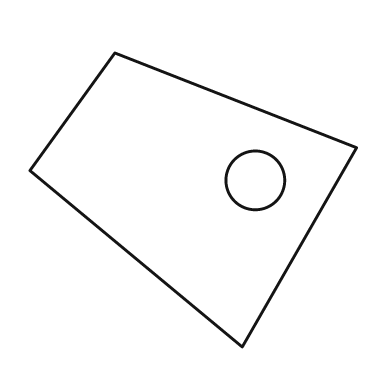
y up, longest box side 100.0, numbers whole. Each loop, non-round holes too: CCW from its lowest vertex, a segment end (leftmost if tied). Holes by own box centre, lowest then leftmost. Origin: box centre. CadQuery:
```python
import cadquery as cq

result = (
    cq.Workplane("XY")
    .moveTo(15.0, -45.0)
    .lineTo(50.0, 16.0)
    .lineTo(-24.0, 45.0)
    .lineTo(-50.0, 9.0)
    .close()
    .moveTo(19.0, 6.0)
    .circle(9.0)
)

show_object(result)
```